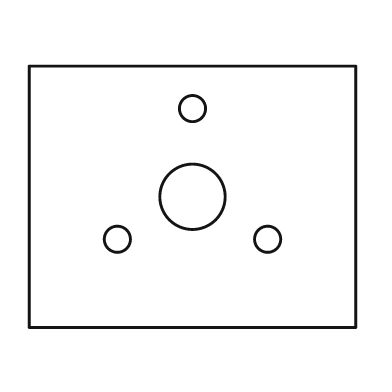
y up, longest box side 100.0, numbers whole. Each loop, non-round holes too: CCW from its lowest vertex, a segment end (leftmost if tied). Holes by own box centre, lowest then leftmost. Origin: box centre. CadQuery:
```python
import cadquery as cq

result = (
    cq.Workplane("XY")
    .moveTo(-50.0, -40.0)
    .lineTo(50.0, -40.0)
    .lineTo(50.0, 40.0)
    .lineTo(-50.0, 40.0)
    .close()
    .moveTo(-23.0, -13.0)
    .circle(4.0)
    .moveTo(23.0, -13.0)
    .circle(4.0)
    .moveTo(0.0, 0.0)
    .circle(10.0)
    .moveTo(0.0, 27.0)
    .circle(4.0)
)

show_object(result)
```